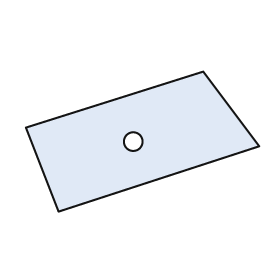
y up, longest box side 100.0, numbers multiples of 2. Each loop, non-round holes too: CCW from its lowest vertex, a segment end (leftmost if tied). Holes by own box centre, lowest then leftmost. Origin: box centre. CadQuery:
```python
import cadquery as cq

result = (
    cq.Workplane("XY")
    .moveTo(-36.0, -30.0)
    .lineTo(50.0, -2.0)
    .lineTo(26.0, 30.0)
    .lineTo(-50.0, 6.0)
    .close()
    .moveTo(-4.0, 0.0)
    .circle(4.0)
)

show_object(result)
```